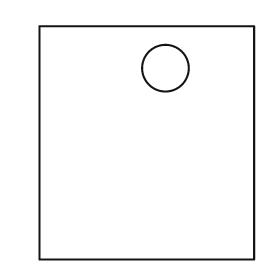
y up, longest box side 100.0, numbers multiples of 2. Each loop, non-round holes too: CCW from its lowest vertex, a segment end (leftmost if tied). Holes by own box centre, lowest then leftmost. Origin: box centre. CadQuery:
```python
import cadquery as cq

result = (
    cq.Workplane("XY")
    .moveTo(-46.0, -50.0)
    .lineTo(46.0, -50.0)
    .lineTo(46.0, 50.0)
    .lineTo(-46.0, 50.0)
    .close()
    .moveTo(8.0, 32.0)
    .circle(10.0)
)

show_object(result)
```